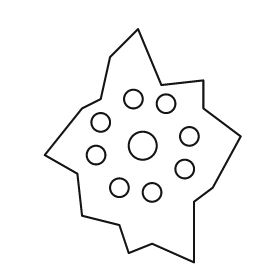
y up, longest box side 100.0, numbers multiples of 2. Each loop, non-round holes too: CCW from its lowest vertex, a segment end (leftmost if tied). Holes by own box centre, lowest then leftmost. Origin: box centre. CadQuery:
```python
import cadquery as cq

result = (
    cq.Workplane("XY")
    .moveTo(22.0, -50.0)
    .lineTo(22.0, -24.0)
    .lineTo(30.0, -18.0)
    .lineTo(42.0, 4.0)
    .lineTo(26.0, 16.0)
    .lineTo(26.0, 28.0)
    .lineTo(8.0, 26.0)
    .lineTo(-2.0, 50.0)
    .lineTo(-14.0, 38.0)
    .lineTo(-18.0, 20.0)
    .lineTo(-26.0, 16.0)
    .lineTo(-42.0, -4.0)
    .lineTo(-28.0, -12.0)
    .lineTo(-26.0, -30.0)
    .lineTo(-10.0, -34.0)
    .lineTo(-6.0, -46.0)
    .lineTo(4.0, -42.0)
    .close()
    .moveTo(4.0, -20.0)
    .circle(4.0)
    .moveTo(-10.0, -18.0)
    .circle(4.0)
    .moveTo(18.0, -10.0)
    .circle(4.0)
    .moveTo(-20.0, -4.0)
    .circle(4.0)
    .moveTo(0.0, 0.0)
    .circle(6.0)
    .moveTo(20.0, 4.0)
    .circle(4.0)
    .moveTo(-18.0, 10.0)
    .circle(4.0)
    .moveTo(10.0, 18.0)
    .circle(4.0)
    .moveTo(-4.0, 20.0)
    .circle(4.0)
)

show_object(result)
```